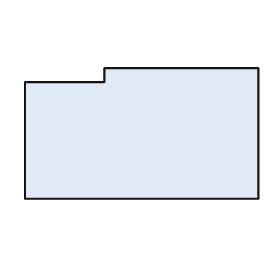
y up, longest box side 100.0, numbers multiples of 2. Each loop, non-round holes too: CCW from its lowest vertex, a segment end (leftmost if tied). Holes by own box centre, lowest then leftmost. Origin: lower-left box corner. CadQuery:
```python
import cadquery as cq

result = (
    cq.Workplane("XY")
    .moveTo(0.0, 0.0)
    .lineTo(100.0, 0.0)
    .lineTo(100.0, 56.0)
    .lineTo(34.0, 56.0)
    .lineTo(34.0, 50.0)
    .lineTo(0.0, 50.0)
    .close()
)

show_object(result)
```